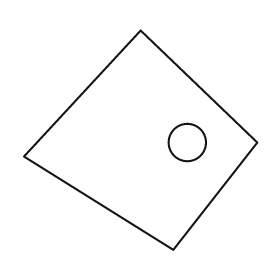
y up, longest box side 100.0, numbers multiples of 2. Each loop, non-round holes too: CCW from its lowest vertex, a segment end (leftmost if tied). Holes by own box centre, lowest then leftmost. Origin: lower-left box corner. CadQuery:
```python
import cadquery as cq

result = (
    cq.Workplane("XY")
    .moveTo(64.0, 0.0)
    .lineTo(100.0, 46.0)
    .lineTo(50.0, 94.0)
    .lineTo(0.0, 40.0)
    .close()
    .moveTo(70.0, 46.0)
    .circle(8.0)
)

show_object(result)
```